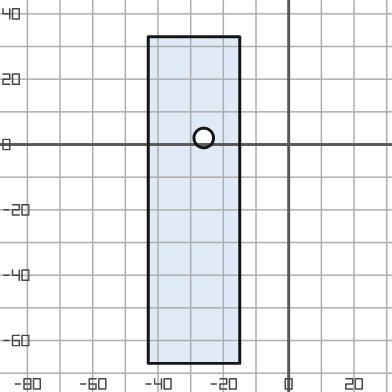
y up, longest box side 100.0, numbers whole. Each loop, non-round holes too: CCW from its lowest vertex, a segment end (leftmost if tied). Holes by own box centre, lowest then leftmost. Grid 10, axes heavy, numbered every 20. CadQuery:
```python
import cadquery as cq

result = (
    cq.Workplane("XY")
    .moveTo(-43.0, -67.0)
    .lineTo(-15.0, -67.0)
    .lineTo(-15.0, 33.0)
    .lineTo(-43.0, 33.0)
    .close()
    .moveTo(-26.0, 2.0)
    .circle(3.0)
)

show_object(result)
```